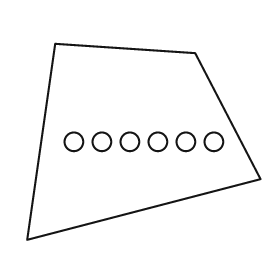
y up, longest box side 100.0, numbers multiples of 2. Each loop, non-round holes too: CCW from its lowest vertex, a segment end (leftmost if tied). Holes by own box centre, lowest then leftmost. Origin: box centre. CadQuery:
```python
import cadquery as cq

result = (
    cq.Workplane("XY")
    .moveTo(-50.0, -42.0)
    .lineTo(50.0, -16.0)
    .lineTo(22.0, 38.0)
    .lineTo(-38.0, 42.0)
    .close()
    .moveTo(-30.0, 0.0)
    .circle(4.0)
    .moveTo(-18.0, 0.0)
    .circle(4.0)
    .moveTo(-6.0, 0.0)
    .circle(4.0)
    .moveTo(6.0, 0.0)
    .circle(4.0)
    .moveTo(18.0, 0.0)
    .circle(4.0)
    .moveTo(30.0, 0.0)
    .circle(4.0)
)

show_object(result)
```